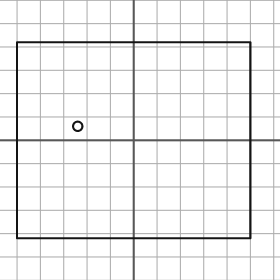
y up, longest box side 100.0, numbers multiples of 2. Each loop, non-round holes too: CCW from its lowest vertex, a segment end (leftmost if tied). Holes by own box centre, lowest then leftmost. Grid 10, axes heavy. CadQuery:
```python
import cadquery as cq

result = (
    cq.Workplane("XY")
    .moveTo(-50.0, -42.0)
    .lineTo(50.0, -42.0)
    .lineTo(50.0, 42.0)
    .lineTo(-50.0, 42.0)
    .close()
    .moveTo(-24.0, 6.0)
    .circle(2.0)
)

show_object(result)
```